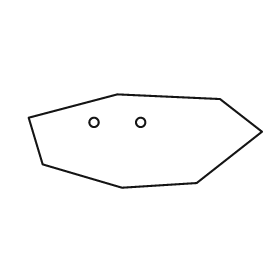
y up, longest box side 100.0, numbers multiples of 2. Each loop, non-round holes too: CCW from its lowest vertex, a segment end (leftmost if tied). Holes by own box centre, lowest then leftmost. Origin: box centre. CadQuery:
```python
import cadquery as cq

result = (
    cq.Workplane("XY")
    .moveTo(-10.0, -20.0)
    .lineTo(22.0, -18.0)
    .lineTo(50.0, 4.0)
    .lineTo(32.0, 18.0)
    .lineTo(-12.0, 20.0)
    .lineTo(-50.0, 10.0)
    .lineTo(-44.0, -10.0)
    .close()
    .moveTo(-22.0, 8.0)
    .circle(2.0)
    .moveTo(-2.0, 8.0)
    .circle(2.0)
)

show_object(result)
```